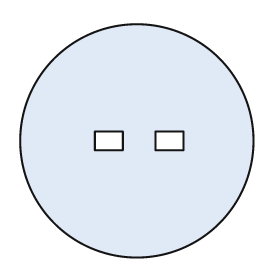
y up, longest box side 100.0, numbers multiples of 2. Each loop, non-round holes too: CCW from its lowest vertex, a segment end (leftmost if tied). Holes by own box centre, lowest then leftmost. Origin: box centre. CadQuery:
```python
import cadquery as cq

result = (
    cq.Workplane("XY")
    .moveTo(0.0, 0.0)
    .circle(50.0)
    .moveTo(-18.0, -4.0)
    .lineTo(-6.0, -4.0)
    .lineTo(-6.0, 4.0)
    .lineTo(-18.0, 4.0)
    .close()
    .moveTo(8.0, -4.0)
    .lineTo(20.0, -4.0)
    .lineTo(20.0, 4.0)
    .lineTo(8.0, 4.0)
    .close()
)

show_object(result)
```